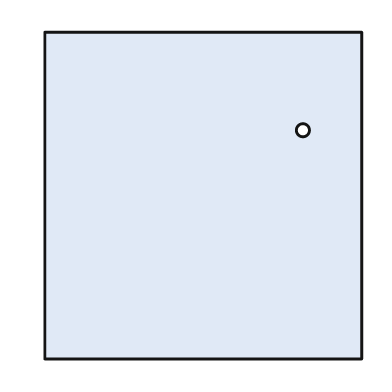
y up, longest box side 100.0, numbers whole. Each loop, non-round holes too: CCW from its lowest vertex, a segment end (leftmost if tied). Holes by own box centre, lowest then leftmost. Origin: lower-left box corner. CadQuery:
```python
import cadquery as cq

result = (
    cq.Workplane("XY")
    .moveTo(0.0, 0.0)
    .lineTo(97.0, 0.0)
    .lineTo(97.0, 100.0)
    .lineTo(0.0, 100.0)
    .close()
    .moveTo(79.0, 70.0)
    .circle(2.0)
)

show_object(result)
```